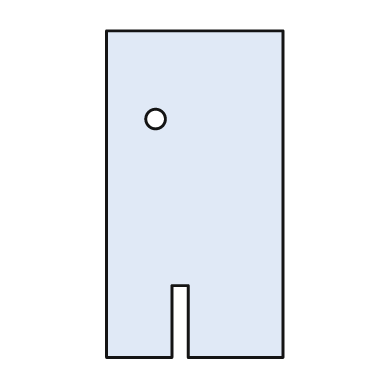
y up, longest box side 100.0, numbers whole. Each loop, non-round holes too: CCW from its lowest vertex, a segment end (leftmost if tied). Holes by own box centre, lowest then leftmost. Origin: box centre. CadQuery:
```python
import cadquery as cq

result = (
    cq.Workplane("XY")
    .moveTo(-27.0, -50.0)
    .lineTo(-7.0, -50.0)
    .lineTo(-7.0, -28.0)
    .lineTo(-2.0, -28.0)
    .lineTo(-2.0, -50.0)
    .lineTo(27.0, -50.0)
    .lineTo(27.0, 50.0)
    .lineTo(-27.0, 50.0)
    .close()
    .moveTo(-12.0, 23.0)
    .circle(3.0)
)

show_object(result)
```